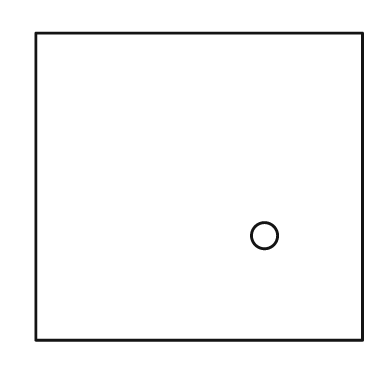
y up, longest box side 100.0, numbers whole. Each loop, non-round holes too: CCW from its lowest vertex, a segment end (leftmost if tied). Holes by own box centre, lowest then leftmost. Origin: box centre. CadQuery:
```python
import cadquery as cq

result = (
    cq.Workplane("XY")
    .moveTo(-50.0, -47.0)
    .lineTo(50.0, -47.0)
    .lineTo(50.0, 47.0)
    .lineTo(-50.0, 47.0)
    .close()
    .moveTo(20.0, -15.0)
    .circle(4.0)
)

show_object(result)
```